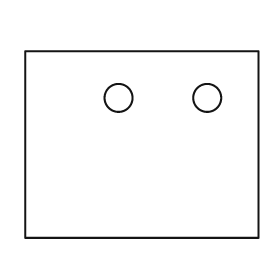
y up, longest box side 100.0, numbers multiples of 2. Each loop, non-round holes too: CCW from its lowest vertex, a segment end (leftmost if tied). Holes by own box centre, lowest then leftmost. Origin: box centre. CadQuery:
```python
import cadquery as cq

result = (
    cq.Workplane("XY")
    .moveTo(-50.0, -40.0)
    .lineTo(50.0, -40.0)
    .lineTo(50.0, 40.0)
    .lineTo(-50.0, 40.0)
    .close()
    .moveTo(-10.0, 20.0)
    .circle(6.0)
    .moveTo(28.0, 20.0)
    .circle(6.0)
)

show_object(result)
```